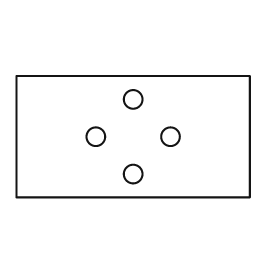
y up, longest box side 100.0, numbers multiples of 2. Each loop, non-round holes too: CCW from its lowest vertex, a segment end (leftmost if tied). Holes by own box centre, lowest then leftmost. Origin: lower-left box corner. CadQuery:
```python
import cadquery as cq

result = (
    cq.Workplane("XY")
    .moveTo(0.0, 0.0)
    .lineTo(100.0, 0.0)
    .lineTo(100.0, 52.0)
    .lineTo(0.0, 52.0)
    .close()
    .moveTo(50.0, 10.0)
    .circle(4.0)
    .moveTo(34.0, 26.0)
    .circle(4.0)
    .moveTo(66.0, 26.0)
    .circle(4.0)
    .moveTo(50.0, 42.0)
    .circle(4.0)
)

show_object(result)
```